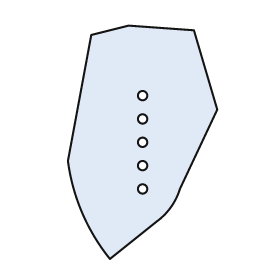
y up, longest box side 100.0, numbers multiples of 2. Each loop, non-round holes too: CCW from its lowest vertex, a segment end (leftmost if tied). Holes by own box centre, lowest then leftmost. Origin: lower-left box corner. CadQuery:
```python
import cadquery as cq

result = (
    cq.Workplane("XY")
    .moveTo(18.0, 0.0)
    .lineTo(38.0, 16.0)
    .threePointArc((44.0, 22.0), (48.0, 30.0))
    .lineTo(64.0, 64.0)
    .lineTo(54.0, 98.0)
    .lineTo(26.0, 100.0)
    .lineTo(10.0, 96.0)
    .lineTo(0.0, 42.0)
    .threePointArc((6.0, 20.0), (18.0, 0.0))
    .close()
    .moveTo(32.0, 30.0)
    .circle(2.0)
    .moveTo(32.0, 40.0)
    .circle(2.0)
    .moveTo(32.0, 50.0)
    .circle(2.0)
    .moveTo(32.0, 60.0)
    .circle(2.0)
    .moveTo(32.0, 70.0)
    .circle(2.0)
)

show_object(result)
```